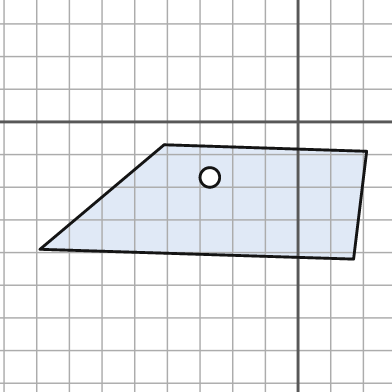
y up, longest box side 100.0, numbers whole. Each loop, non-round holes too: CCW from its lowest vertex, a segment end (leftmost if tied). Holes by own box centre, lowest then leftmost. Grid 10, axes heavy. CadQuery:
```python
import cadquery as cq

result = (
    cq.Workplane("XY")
    .moveTo(17.0, -42.0)
    .lineTo(21.0, -9.0)
    .lineTo(-41.0, -7.0)
    .lineTo(-79.0, -39.0)
    .close()
    .moveTo(-27.0, -17.0)
    .circle(3.0)
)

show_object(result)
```